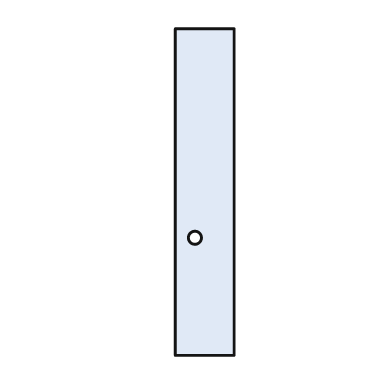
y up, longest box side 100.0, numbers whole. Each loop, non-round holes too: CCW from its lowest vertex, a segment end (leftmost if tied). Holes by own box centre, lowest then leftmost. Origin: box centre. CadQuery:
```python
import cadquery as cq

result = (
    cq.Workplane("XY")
    .moveTo(-9.0, -50.0)
    .lineTo(9.0, -50.0)
    .lineTo(9.0, 50.0)
    .lineTo(-9.0, 50.0)
    .close()
    .moveTo(-3.0, -14.0)
    .circle(2.0)
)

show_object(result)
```